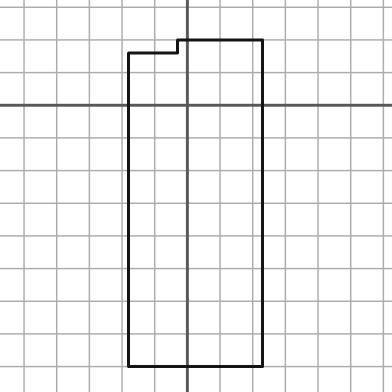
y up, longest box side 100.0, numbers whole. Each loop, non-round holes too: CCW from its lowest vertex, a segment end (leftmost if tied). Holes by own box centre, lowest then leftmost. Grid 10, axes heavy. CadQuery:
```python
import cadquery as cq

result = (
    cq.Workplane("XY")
    .moveTo(-18.0, -80.0)
    .lineTo(23.0, -80.0)
    .lineTo(23.0, 20.0)
    .lineTo(-3.0, 20.0)
    .lineTo(-3.0, 16.0)
    .lineTo(-18.0, 16.0)
    .close()
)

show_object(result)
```